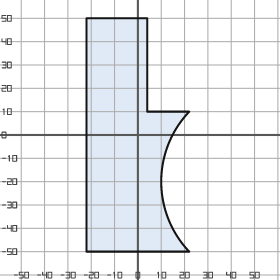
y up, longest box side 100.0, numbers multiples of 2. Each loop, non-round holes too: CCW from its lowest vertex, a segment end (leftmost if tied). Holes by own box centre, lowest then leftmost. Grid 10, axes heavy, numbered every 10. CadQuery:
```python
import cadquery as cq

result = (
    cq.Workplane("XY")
    .moveTo(-22.0, -50.0)
    .lineTo(22.0, -50.0)
    .threePointArc((10.0, -20.0), (22.0, 10.0))
    .lineTo(4.0, 10.0)
    .lineTo(4.0, 50.0)
    .lineTo(-22.0, 50.0)
    .close()
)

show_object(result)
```